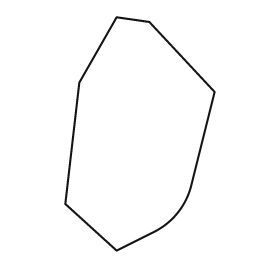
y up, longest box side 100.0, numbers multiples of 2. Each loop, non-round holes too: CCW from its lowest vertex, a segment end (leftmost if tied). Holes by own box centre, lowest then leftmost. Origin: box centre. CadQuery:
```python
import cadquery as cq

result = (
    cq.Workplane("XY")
    .moveTo(-10.0, -50.0)
    .lineTo(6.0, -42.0)
    .threePointArc((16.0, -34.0), (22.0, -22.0))
    .lineTo(32.0, 18.0)
    .lineTo(4.0, 48.0)
    .lineTo(-10.0, 50.0)
    .lineTo(-26.0, 22.0)
    .lineTo(-32.0, -30.0)
    .close()
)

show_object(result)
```